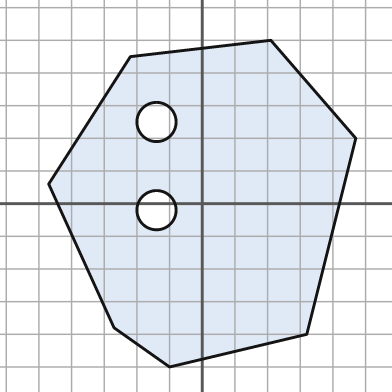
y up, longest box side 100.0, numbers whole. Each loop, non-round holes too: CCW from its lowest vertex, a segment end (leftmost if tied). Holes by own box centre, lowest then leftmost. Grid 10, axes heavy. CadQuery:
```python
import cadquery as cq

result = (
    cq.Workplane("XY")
    .moveTo(-10.0, -50.0)
    .lineTo(32.0, -40.0)
    .lineTo(47.0, 20.0)
    .lineTo(21.0, 50.0)
    .lineTo(-22.0, 45.0)
    .lineTo(-47.0, 6.0)
    .lineTo(-27.0, -38.0)
    .close()
    .moveTo(-14.0, -2.0)
    .circle(6.0)
    .moveTo(-14.0, 25.0)
    .circle(6.0)
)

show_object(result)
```